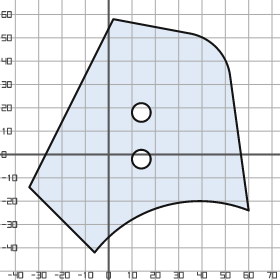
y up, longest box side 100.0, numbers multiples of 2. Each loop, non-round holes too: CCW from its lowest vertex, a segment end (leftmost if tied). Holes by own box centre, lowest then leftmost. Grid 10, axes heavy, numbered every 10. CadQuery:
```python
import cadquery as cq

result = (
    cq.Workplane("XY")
    .moveTo(-6.0, -42.0)
    .threePointArc((24.0, -22.0), (60.0, -24.0))
    .lineTo(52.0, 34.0)
    .threePointArc((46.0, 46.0), (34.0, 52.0))
    .lineTo(2.0, 58.0)
    .lineTo(-34.0, -14.0)
    .close()
    .moveTo(14.0, -2.0)
    .circle(4.0)
    .moveTo(14.0, 18.0)
    .circle(4.0)
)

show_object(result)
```